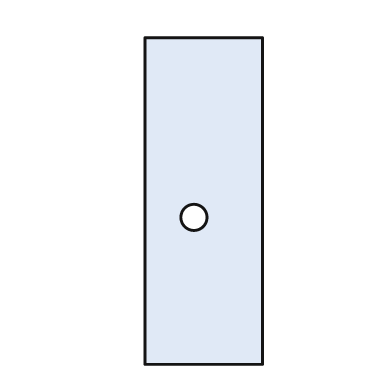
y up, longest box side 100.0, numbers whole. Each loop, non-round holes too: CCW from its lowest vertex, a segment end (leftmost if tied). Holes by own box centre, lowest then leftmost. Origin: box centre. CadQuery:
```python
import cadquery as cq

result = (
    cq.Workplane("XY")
    .moveTo(-18.0, -50.0)
    .lineTo(18.0, -50.0)
    .lineTo(18.0, 50.0)
    .lineTo(-18.0, 50.0)
    .close()
    .moveTo(-3.0, -5.0)
    .circle(4.0)
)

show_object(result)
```